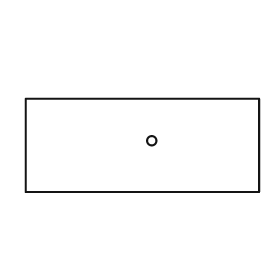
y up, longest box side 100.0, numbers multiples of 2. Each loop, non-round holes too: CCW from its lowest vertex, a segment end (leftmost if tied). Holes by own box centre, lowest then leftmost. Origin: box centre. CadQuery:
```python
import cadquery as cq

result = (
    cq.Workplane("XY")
    .moveTo(-50.0, -20.0)
    .lineTo(50.0, -20.0)
    .lineTo(50.0, 20.0)
    .lineTo(-50.0, 20.0)
    .close()
    .moveTo(4.0, 2.0)
    .circle(2.0)
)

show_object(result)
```